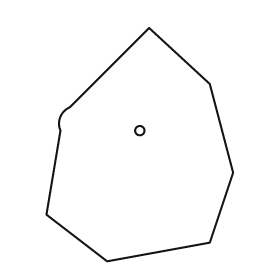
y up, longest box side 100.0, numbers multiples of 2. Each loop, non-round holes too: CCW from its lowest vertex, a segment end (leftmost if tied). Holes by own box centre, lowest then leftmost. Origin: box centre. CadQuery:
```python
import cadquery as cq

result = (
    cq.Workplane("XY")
    .moveTo(-14.0, -50.0)
    .lineTo(30.0, -42.0)
    .lineTo(40.0, -12.0)
    .lineTo(30.0, 26.0)
    .lineTo(4.0, 50.0)
    .lineTo(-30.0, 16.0)
    .threePointArc((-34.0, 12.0), (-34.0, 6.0))
    .lineTo(-40.0, -30.0)
    .close()
    .moveTo(0.0, 6.0)
    .circle(2.0)
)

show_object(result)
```